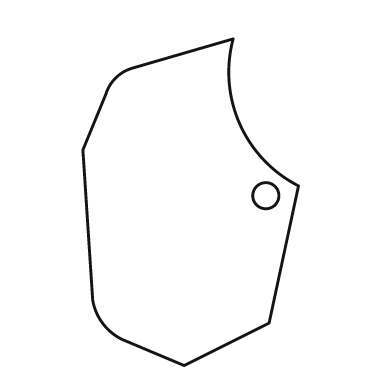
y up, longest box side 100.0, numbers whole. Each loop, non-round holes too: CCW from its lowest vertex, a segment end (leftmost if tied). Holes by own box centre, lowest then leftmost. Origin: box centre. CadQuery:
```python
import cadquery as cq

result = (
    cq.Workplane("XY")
    .moveTo(-2.0, -50.0)
    .lineTo(24.0, -37.0)
    .lineTo(33.0, 5.0)
    .threePointArc((15.0, 24.0), (13.0, 50.0))
    .lineTo(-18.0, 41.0)
    .threePointArc((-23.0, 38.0), (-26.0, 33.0))
    .lineTo(-33.0, 16.0)
    .lineTo(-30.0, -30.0)
    .threePointArc((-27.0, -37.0), (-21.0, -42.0))
    .close()
    .moveTo(23.0, 2.0)
    .circle(4.0)
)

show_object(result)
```